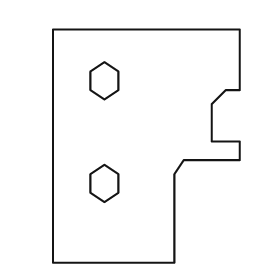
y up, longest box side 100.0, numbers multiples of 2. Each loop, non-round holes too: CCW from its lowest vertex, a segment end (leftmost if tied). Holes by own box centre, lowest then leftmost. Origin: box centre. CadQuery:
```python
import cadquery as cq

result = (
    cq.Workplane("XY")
    .moveTo(-40.0, -50.0)
    .lineTo(12.0, -50.0)
    .lineTo(12.0, -12.0)
    .lineTo(16.0, -6.0)
    .lineTo(40.0, -6.0)
    .lineTo(40.0, 2.0)
    .lineTo(28.0, 2.0)
    .lineTo(28.0, 18.0)
    .lineTo(34.0, 24.0)
    .lineTo(40.0, 24.0)
    .lineTo(40.0, 50.0)
    .lineTo(-40.0, 50.0)
    .close()
    .moveTo(-18.0, -24.0)
    .lineTo(-12.0, -20.0)
    .lineTo(-12.0, -12.0)
    .lineTo(-18.0, -8.0)
    .lineTo(-24.0, -12.0)
    .lineTo(-24.0, -20.0)
    .close()
    .moveTo(-18.0, 20.0)
    .lineTo(-12.0, 24.0)
    .lineTo(-12.0, 32.0)
    .lineTo(-18.0, 36.0)
    .lineTo(-24.0, 32.0)
    .lineTo(-24.0, 24.0)
    .close()
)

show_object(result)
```